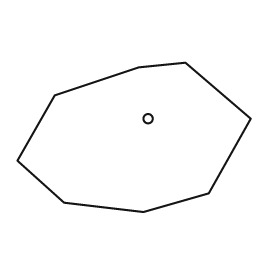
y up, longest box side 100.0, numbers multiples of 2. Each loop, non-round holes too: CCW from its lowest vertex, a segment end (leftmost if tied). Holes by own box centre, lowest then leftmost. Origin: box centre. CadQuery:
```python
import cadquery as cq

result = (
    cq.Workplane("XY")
    .moveTo(4.0, -32.0)
    .lineTo(32.0, -24.0)
    .lineTo(50.0, 8.0)
    .lineTo(22.0, 32.0)
    .lineTo(2.0, 30.0)
    .lineTo(-34.0, 18.0)
    .lineTo(-50.0, -10.0)
    .lineTo(-30.0, -28.0)
    .close()
    .moveTo(6.0, 8.0)
    .circle(2.0)
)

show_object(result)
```